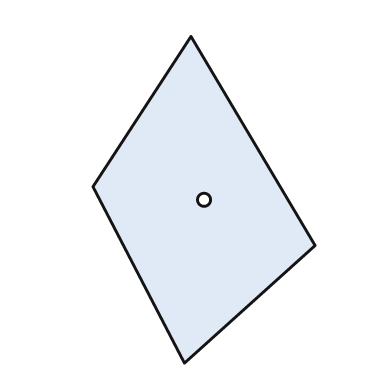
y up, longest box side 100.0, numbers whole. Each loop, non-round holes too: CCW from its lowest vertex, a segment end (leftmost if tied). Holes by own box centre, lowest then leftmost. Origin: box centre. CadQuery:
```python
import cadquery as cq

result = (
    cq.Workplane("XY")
    .moveTo(-6.0, -50.0)
    .lineTo(34.0, -14.0)
    .lineTo(-4.0, 50.0)
    .lineTo(-34.0, 4.0)
    .close()
    .moveTo(0.0, 0.0)
    .circle(2.0)
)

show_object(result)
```